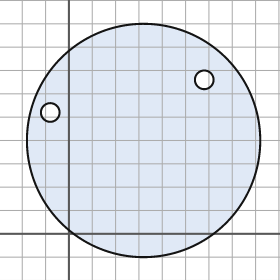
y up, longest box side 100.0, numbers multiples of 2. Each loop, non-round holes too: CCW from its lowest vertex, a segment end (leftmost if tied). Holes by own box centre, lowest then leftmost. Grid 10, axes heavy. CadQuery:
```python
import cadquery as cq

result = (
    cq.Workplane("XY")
    .moveTo(32.0, 40.0)
    .circle(50.0)
    .moveTo(-8.0, 52.0)
    .circle(4.0)
    .moveTo(58.0, 66.0)
    .circle(4.0)
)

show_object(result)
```